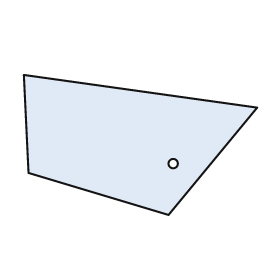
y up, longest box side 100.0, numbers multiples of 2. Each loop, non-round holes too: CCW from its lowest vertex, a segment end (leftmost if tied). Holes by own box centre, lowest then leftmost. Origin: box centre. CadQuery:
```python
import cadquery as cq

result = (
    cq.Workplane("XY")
    .moveTo(12.0, -30.0)
    .lineTo(50.0, 16.0)
    .lineTo(-50.0, 30.0)
    .lineTo(-48.0, -12.0)
    .close()
    .moveTo(14.0, -8.0)
    .circle(2.0)
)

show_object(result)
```